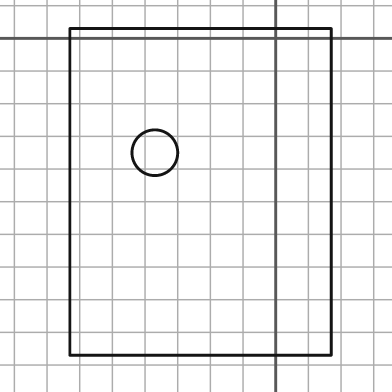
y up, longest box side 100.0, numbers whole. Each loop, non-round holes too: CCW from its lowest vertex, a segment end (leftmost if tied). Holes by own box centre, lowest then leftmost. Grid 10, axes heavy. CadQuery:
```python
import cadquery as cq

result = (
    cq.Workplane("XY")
    .moveTo(-63.0, -97.0)
    .lineTo(17.0, -97.0)
    .lineTo(17.0, 3.0)
    .lineTo(-63.0, 3.0)
    .close()
    .moveTo(-37.0, -35.0)
    .circle(7.0)
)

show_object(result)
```